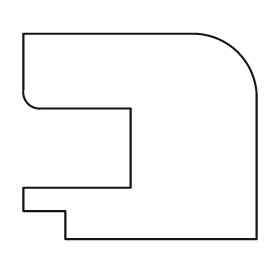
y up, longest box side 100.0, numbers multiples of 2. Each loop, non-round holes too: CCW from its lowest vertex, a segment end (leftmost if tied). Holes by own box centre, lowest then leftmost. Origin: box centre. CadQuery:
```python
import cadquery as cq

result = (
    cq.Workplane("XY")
    .moveTo(-32.0, -44.0)
    .lineTo(50.0, -44.0)
    .lineTo(50.0, 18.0)
    .threePointArc((42.0, 36.0), (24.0, 44.0))
    .lineTo(-50.0, 44.0)
    .lineTo(-50.0, 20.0)
    .threePointArc((-48.0, 14.0), (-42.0, 12.0))
    .lineTo(-4.0, 12.0)
    .lineTo(-4.0, -22.0)
    .lineTo(-50.0, -22.0)
    .lineTo(-50.0, -32.0)
    .lineTo(-32.0, -32.0)
    .close()
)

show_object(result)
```